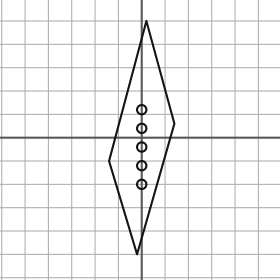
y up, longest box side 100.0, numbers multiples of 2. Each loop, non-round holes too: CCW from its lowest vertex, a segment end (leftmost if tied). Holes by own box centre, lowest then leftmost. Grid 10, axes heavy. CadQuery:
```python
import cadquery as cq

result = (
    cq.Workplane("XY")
    .moveTo(-2.0, -50.0)
    .lineTo(14.0, 6.0)
    .lineTo(2.0, 50.0)
    .lineTo(-14.0, -10.0)
    .close()
    .moveTo(0.0, -20.0)
    .circle(2.0)
    .moveTo(0.0, -12.0)
    .circle(2.0)
    .moveTo(0.0, -4.0)
    .circle(2.0)
    .moveTo(0.0, 4.0)
    .circle(2.0)
    .moveTo(0.0, 12.0)
    .circle(2.0)
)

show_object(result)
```